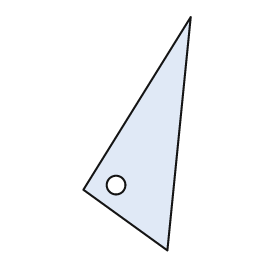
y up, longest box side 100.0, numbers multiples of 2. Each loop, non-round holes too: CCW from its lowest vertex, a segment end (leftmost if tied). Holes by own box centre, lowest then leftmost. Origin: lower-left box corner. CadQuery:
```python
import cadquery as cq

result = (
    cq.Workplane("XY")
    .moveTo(36.0, 0.0)
    .lineTo(46.0, 100.0)
    .lineTo(0.0, 26.0)
    .close()
    .moveTo(14.0, 28.0)
    .circle(4.0)
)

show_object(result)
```